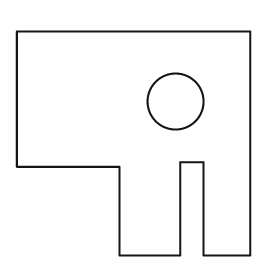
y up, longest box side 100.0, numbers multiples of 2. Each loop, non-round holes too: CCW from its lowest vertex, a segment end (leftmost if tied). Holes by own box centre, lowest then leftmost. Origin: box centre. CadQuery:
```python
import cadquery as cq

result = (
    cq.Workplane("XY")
    .moveTo(-6.0, -48.0)
    .lineTo(20.0, -48.0)
    .lineTo(20.0, -8.0)
    .lineTo(30.0, -8.0)
    .lineTo(30.0, -48.0)
    .lineTo(50.0, -48.0)
    .lineTo(50.0, 48.0)
    .lineTo(-50.0, 48.0)
    .lineTo(-50.0, -10.0)
    .lineTo(-6.0, -10.0)
    .close()
    .moveTo(18.0, 18.0)
    .circle(12.0)
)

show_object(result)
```